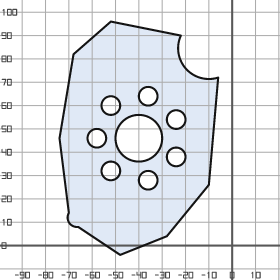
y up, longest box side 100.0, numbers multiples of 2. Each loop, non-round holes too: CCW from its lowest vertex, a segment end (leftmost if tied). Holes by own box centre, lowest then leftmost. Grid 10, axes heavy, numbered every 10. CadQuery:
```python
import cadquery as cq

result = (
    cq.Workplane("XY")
    .moveTo(-48.0, -4.0)
    .lineTo(-28.0, 4.0)
    .lineTo(-10.0, 26.0)
    .lineTo(-6.0, 72.0)
    .threePointArc((-20.0, 76.0), (-22.0, 90.0))
    .lineTo(-52.0, 96.0)
    .lineTo(-68.0, 82.0)
    .lineTo(-74.0, 46.0)
    .lineTo(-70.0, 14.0)
    .threePointArc((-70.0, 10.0), (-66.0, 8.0))
    .close()
    .moveTo(-36.0, 28.0)
    .circle(4.0)
    .moveTo(-52.0, 32.0)
    .circle(4.0)
    .moveTo(-24.0, 38.0)
    .circle(4.0)
    .moveTo(-58.0, 46.0)
    .circle(4.0)
    .moveTo(-40.0, 46.0)
    .circle(10.0)
    .moveTo(-24.0, 54.0)
    .circle(4.0)
    .moveTo(-52.0, 60.0)
    .circle(4.0)
    .moveTo(-36.0, 64.0)
    .circle(4.0)
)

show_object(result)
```